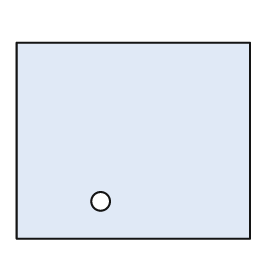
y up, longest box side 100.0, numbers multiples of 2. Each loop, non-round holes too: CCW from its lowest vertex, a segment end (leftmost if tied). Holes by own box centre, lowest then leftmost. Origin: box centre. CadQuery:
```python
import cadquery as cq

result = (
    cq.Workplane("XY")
    .moveTo(-50.0, -42.0)
    .lineTo(50.0, -42.0)
    .lineTo(50.0, 42.0)
    .lineTo(-50.0, 42.0)
    .close()
    .moveTo(-14.0, -26.0)
    .circle(4.0)
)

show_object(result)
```